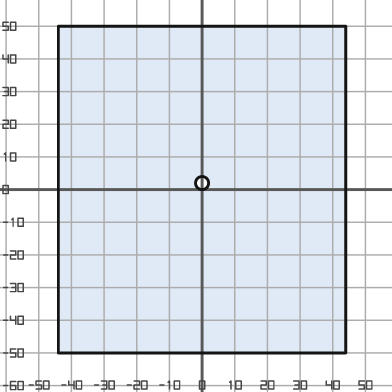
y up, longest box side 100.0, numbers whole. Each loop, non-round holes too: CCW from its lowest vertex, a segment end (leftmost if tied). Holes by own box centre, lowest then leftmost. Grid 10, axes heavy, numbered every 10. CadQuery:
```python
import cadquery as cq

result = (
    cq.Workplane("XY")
    .moveTo(-44.0, -50.0)
    .lineTo(44.0, -50.0)
    .lineTo(44.0, 50.0)
    .lineTo(-44.0, 50.0)
    .close()
    .moveTo(0.0, 2.0)
    .circle(2.0)
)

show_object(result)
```